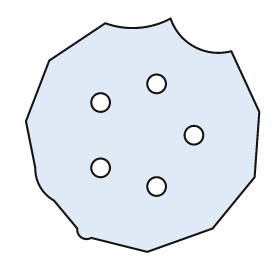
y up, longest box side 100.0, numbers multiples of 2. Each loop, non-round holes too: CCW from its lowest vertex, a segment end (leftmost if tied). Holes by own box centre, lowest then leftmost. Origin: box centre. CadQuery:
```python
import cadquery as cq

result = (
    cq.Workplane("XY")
    .moveTo(2.0, -50.0)
    .lineTo(30.0, -40.0)
    .lineTo(48.0, -18.0)
    .lineTo(50.0, 10.0)
    .lineTo(38.0, 36.0)
    .threePointArc((22.0, 38.0), (12.0, 50.0))
    .threePointArc((-2.0, 46.0), (-16.0, 48.0))
    .lineTo(-40.0, 32.0)
    .lineTo(-50.0, 6.0)
    .lineTo(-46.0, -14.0)
    .threePointArc((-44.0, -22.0), (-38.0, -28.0))
    .lineTo(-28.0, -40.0)
    .threePointArc((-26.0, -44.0), (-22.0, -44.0))
    .close()
    .moveTo(6.0, -22.0)
    .circle(4.0)
    .moveTo(-18.0, -14.0)
    .circle(4.0)
    .moveTo(22.0, 0.0)
    .circle(4.0)
    .moveTo(-18.0, 14.0)
    .circle(4.0)
    .moveTo(6.0, 22.0)
    .circle(4.0)
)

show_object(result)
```